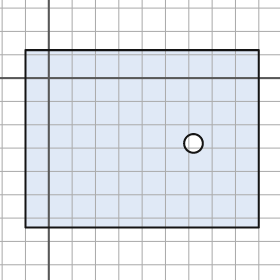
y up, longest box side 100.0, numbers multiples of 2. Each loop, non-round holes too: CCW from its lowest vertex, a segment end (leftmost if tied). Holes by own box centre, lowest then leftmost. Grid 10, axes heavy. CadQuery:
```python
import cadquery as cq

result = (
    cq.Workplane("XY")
    .moveTo(-10.0, -64.0)
    .lineTo(90.0, -64.0)
    .lineTo(90.0, 12.0)
    .lineTo(-10.0, 12.0)
    .close()
    .moveTo(62.0, -28.0)
    .circle(4.0)
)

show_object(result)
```